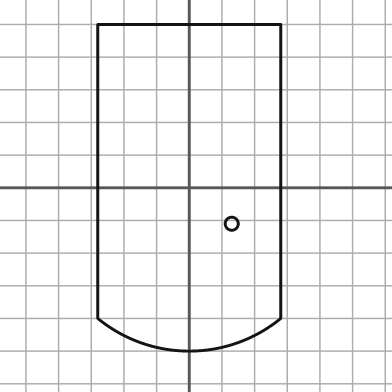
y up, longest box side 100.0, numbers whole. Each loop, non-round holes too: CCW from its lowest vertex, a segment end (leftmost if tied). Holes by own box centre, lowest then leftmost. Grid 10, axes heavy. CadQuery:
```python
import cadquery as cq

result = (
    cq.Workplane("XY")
    .moveTo(-28.0, -40.0)
    .threePointArc((0.0, -50.0), (28.0, -40.0))
    .lineTo(28.0, 50.0)
    .lineTo(-28.0, 50.0)
    .close()
    .moveTo(13.0, -11.0)
    .circle(2.0)
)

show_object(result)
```